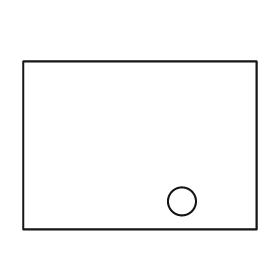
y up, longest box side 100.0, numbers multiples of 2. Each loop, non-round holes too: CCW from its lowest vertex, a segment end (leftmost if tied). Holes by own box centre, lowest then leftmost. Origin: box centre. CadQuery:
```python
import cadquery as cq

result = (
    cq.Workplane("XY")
    .moveTo(-50.0, -36.0)
    .lineTo(50.0, -36.0)
    .lineTo(50.0, 36.0)
    .lineTo(-50.0, 36.0)
    .close()
    .moveTo(18.0, -24.0)
    .circle(6.0)
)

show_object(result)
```